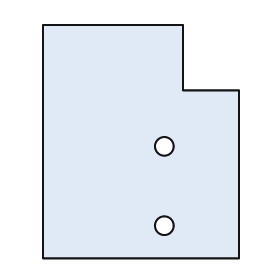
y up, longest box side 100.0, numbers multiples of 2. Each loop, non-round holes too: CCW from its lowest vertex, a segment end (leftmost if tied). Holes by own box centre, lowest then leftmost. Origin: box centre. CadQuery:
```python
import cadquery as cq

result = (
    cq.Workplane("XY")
    .moveTo(-42.0, -50.0)
    .lineTo(42.0, -50.0)
    .lineTo(42.0, 22.0)
    .lineTo(18.0, 22.0)
    .lineTo(18.0, 50.0)
    .lineTo(-42.0, 50.0)
    .close()
    .moveTo(10.0, -36.0)
    .circle(4.0)
    .moveTo(10.0, -2.0)
    .circle(4.0)
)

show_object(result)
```